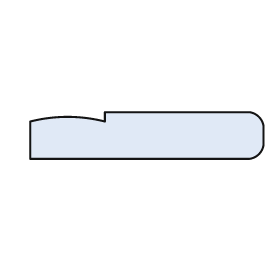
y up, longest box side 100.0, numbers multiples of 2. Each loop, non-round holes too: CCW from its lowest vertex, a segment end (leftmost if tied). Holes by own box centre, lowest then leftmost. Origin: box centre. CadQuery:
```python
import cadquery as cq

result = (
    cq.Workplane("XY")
    .moveTo(-50.0, -10.0)
    .lineTo(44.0, -10.0)
    .threePointArc((48.0, -8.0), (50.0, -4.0))
    .lineTo(50.0, 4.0)
    .threePointArc((48.0, 8.0), (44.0, 10.0))
    .lineTo(-18.0, 10.0)
    .lineTo(-18.0, 6.0)
    .threePointArc((-34.0, 8.0), (-50.0, 6.0))
    .close()
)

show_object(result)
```